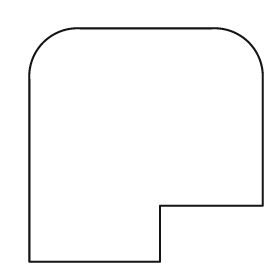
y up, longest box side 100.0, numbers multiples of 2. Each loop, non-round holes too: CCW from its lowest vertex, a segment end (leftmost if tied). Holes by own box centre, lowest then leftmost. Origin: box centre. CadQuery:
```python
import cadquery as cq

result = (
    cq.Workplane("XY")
    .moveTo(-50.0, -50.0)
    .lineTo(6.0, -50.0)
    .lineTo(6.0, -26.0)
    .lineTo(50.0, -26.0)
    .lineTo(50.0, 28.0)
    .threePointArc((44.0, 44.0), (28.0, 50.0))
    .lineTo(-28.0, 50.0)
    .threePointArc((-44.0, 44.0), (-50.0, 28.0))
    .close()
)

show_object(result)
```